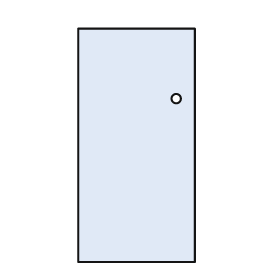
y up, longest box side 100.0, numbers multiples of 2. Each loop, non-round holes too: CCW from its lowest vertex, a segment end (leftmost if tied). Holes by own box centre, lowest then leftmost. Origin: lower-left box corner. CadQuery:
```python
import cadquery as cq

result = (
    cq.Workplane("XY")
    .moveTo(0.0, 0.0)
    .lineTo(50.0, 0.0)
    .lineTo(50.0, 100.0)
    .lineTo(0.0, 100.0)
    .close()
    .moveTo(42.0, 70.0)
    .circle(2.0)
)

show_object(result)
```